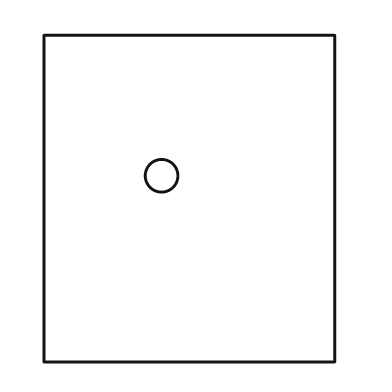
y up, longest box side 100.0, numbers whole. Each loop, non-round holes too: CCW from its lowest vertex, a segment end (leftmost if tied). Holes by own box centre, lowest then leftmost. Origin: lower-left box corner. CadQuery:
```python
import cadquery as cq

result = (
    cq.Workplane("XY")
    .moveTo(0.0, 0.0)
    .lineTo(89.0, 0.0)
    .lineTo(89.0, 100.0)
    .lineTo(0.0, 100.0)
    .close()
    .moveTo(36.0, 57.0)
    .circle(5.0)
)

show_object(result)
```